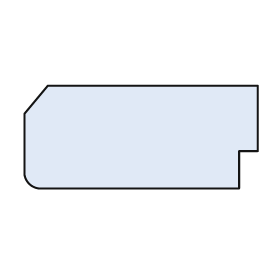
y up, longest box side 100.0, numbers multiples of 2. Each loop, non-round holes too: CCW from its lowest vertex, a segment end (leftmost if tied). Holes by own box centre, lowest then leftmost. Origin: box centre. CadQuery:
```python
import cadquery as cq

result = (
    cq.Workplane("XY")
    .moveTo(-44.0, -22.0)
    .lineTo(42.0, -22.0)
    .lineTo(42.0, -6.0)
    .lineTo(50.0, -6.0)
    .lineTo(50.0, 22.0)
    .lineTo(-40.0, 22.0)
    .lineTo(-50.0, 10.0)
    .lineTo(-50.0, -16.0)
    .threePointArc((-48.0, -20.0), (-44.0, -22.0))
    .close()
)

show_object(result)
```